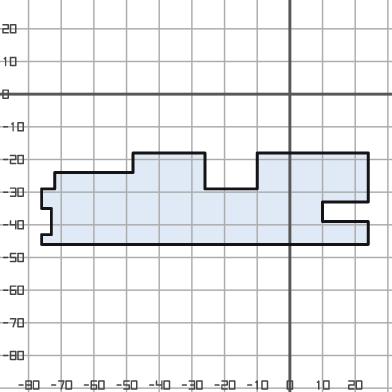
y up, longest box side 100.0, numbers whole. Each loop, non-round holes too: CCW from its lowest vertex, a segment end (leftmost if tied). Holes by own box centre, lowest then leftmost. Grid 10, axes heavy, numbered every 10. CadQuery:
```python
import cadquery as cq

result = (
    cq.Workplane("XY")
    .moveTo(-76.0, -46.0)
    .lineTo(24.0, -46.0)
    .lineTo(24.0, -39.0)
    .lineTo(10.0, -39.0)
    .lineTo(10.0, -33.0)
    .lineTo(24.0, -33.0)
    .lineTo(24.0, -18.0)
    .lineTo(-10.0, -18.0)
    .lineTo(-10.0, -29.0)
    .lineTo(-26.0, -29.0)
    .lineTo(-26.0, -18.0)
    .lineTo(-48.0, -18.0)
    .lineTo(-48.0, -24.0)
    .lineTo(-72.0, -24.0)
    .lineTo(-72.0, -29.0)
    .lineTo(-76.0, -29.0)
    .lineTo(-76.0, -35.0)
    .lineTo(-73.0, -35.0)
    .lineTo(-73.0, -43.0)
    .lineTo(-76.0, -43.0)
    .close()
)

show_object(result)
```